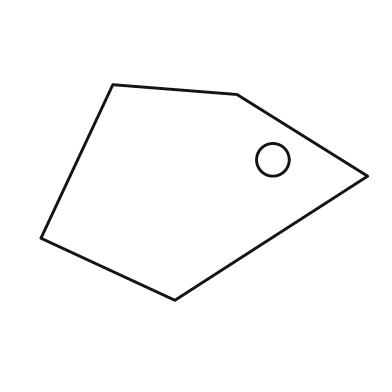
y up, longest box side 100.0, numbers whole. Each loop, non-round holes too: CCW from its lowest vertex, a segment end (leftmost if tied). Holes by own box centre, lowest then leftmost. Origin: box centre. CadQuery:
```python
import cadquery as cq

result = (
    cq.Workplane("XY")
    .moveTo(-9.0, -33.0)
    .lineTo(50.0, 5.0)
    .lineTo(10.0, 30.0)
    .lineTo(-28.0, 33.0)
    .lineTo(-50.0, -14.0)
    .close()
    .moveTo(21.0, 10.0)
    .circle(5.0)
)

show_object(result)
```